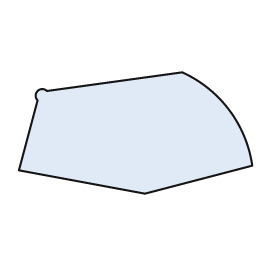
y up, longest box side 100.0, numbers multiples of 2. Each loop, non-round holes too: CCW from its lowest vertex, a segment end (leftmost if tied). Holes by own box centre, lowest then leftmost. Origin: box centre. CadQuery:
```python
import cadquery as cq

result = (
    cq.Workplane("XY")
    .moveTo(4.0, -26.0)
    .lineTo(50.0, -14.0)
    .threePointArc((40.0, 10.0), (20.0, 26.0))
    .lineTo(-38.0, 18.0)
    .threePointArc((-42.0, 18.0), (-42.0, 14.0))
    .lineTo(-50.0, -16.0)
    .close()
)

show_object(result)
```